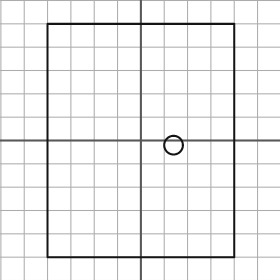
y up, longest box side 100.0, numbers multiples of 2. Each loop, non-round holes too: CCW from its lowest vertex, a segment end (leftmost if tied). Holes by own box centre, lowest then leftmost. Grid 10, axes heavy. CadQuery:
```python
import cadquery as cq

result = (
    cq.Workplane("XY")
    .moveTo(-40.0, -50.0)
    .lineTo(40.0, -50.0)
    .lineTo(40.0, 50.0)
    .lineTo(-40.0, 50.0)
    .close()
    .moveTo(14.0, -2.0)
    .circle(4.0)
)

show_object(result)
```